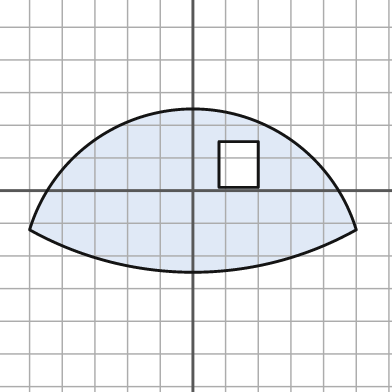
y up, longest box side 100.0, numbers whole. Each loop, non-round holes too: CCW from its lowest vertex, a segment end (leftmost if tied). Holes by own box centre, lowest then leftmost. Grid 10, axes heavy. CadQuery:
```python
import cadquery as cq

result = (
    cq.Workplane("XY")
    .moveTo(-50.0, -12.0)
    .threePointArc((0.0, -25.0), (50.0, -12.0))
    .threePointArc((0.0, 25.0), (-50.0, -12.0))
    .close()
    .moveTo(8.0, 1.0)
    .lineTo(20.0, 1.0)
    .lineTo(20.0, 15.0)
    .lineTo(8.0, 15.0)
    .close()
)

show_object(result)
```